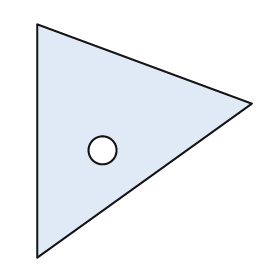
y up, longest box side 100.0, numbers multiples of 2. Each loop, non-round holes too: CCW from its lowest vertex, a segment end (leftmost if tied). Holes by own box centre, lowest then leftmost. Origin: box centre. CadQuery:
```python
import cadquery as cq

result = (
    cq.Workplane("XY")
    .moveTo(-46.0, -50.0)
    .lineTo(46.0, 16.0)
    .lineTo(-46.0, 50.0)
    .close()
    .moveTo(-18.0, -4.0)
    .circle(6.0)
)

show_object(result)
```